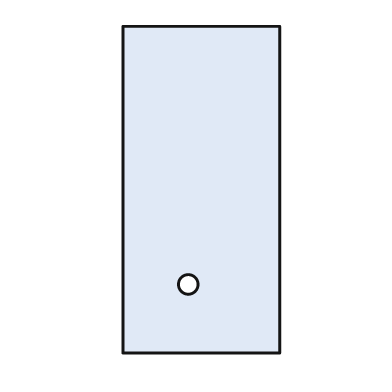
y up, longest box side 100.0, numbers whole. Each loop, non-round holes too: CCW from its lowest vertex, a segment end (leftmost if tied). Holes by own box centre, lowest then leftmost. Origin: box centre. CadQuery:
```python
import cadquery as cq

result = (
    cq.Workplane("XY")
    .moveTo(-24.0, -50.0)
    .lineTo(24.0, -50.0)
    .lineTo(24.0, 50.0)
    .lineTo(-24.0, 50.0)
    .close()
    .moveTo(-4.0, -29.0)
    .circle(3.0)
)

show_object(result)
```